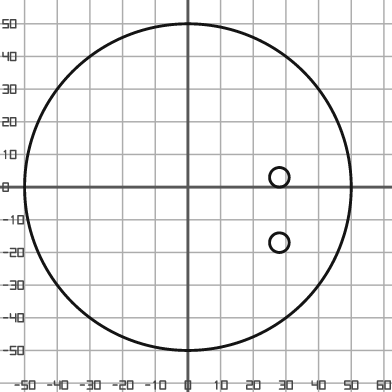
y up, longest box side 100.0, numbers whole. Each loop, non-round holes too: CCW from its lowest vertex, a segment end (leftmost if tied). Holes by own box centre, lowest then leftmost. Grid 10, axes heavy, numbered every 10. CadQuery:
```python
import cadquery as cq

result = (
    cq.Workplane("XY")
    .moveTo(0.0, 0.0)
    .circle(50.0)
    .moveTo(28.0, -17.0)
    .circle(3.0)
    .moveTo(28.0, 3.0)
    .circle(3.0)
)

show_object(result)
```